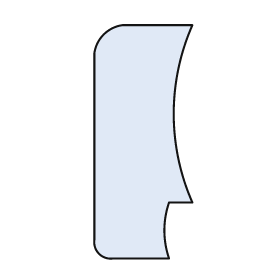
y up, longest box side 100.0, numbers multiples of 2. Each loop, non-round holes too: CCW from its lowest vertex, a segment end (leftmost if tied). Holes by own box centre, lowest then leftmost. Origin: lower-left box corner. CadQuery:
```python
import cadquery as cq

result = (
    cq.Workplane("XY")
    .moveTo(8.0, 0.0)
    .lineTo(32.0, 0.0)
    .threePointArc((30.0, 12.0), (32.0, 24.0))
    .lineTo(42.0, 24.0)
    .threePointArc((34.0, 62.0), (42.0, 100.0))
    .lineTo(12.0, 100.0)
    .threePointArc((4.0, 96.0), (0.0, 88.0))
    .lineTo(0.0, 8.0)
    .threePointArc((2.0, 2.0), (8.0, 0.0))
    .close()
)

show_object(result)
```